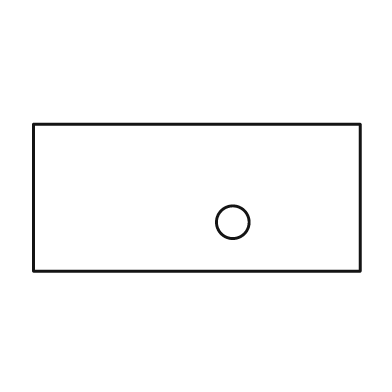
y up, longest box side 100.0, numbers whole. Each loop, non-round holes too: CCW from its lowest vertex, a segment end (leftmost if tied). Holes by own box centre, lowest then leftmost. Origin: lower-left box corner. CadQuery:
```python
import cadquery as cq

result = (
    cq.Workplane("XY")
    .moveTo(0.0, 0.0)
    .lineTo(100.0, 0.0)
    .lineTo(100.0, 45.0)
    .lineTo(0.0, 45.0)
    .close()
    .moveTo(61.0, 15.0)
    .circle(5.0)
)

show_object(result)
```